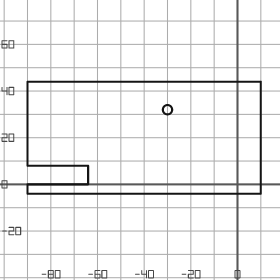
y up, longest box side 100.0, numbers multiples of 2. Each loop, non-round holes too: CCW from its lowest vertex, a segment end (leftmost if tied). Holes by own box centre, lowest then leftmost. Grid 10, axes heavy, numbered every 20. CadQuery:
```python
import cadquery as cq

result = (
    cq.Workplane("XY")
    .moveTo(-90.0, -4.0)
    .lineTo(10.0, -4.0)
    .lineTo(10.0, 44.0)
    .lineTo(-90.0, 44.0)
    .lineTo(-90.0, 8.0)
    .lineTo(-64.0, 8.0)
    .lineTo(-64.0, 0.0)
    .lineTo(-90.0, 0.0)
    .close()
    .moveTo(-30.0, 32.0)
    .circle(2.0)
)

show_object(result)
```